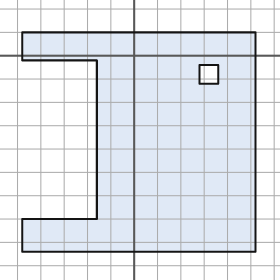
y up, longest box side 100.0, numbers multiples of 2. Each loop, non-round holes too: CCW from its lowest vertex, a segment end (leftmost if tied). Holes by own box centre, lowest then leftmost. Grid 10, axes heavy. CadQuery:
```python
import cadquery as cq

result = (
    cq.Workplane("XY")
    .moveTo(-48.0, -84.0)
    .lineTo(52.0, -84.0)
    .lineTo(52.0, 10.0)
    .lineTo(-48.0, 10.0)
    .lineTo(-48.0, -2.0)
    .lineTo(-16.0, -2.0)
    .lineTo(-16.0, -70.0)
    .lineTo(-48.0, -70.0)
    .close()
    .moveTo(28.0, -12.0)
    .lineTo(36.0, -12.0)
    .lineTo(36.0, -4.0)
    .lineTo(28.0, -4.0)
    .close()
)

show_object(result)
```